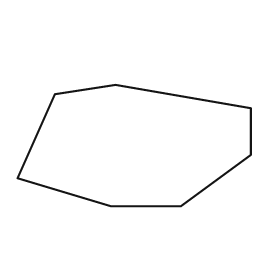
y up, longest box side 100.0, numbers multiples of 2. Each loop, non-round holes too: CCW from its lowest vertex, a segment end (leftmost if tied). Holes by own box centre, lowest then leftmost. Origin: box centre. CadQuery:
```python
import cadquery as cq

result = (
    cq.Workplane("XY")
    .moveTo(-10.0, -26.0)
    .lineTo(20.0, -26.0)
    .lineTo(50.0, -4.0)
    .lineTo(50.0, 16.0)
    .lineTo(-8.0, 26.0)
    .lineTo(-34.0, 22.0)
    .lineTo(-50.0, -14.0)
    .close()
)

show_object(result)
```